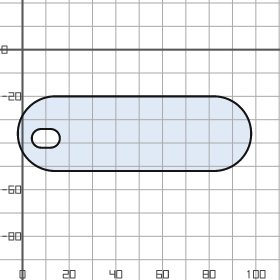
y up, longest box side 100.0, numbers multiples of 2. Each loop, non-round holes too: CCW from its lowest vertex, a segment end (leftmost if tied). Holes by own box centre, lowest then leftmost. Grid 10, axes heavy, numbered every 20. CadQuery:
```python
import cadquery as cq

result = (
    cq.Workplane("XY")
    .moveTo(14.0, -52.0)
    .lineTo(82.0, -52.0)
    .threePointArc((98.0, -36.0), (82.0, -20.0))
    .lineTo(14.0, -20.0)
    .threePointArc((-2.0, -36.0), (14.0, -52.0))
    .close()
    .moveTo(8.0, -42.0)
    .lineTo(12.0, -42.0)
    .threePointArc((16.0, -38.0), (12.0, -34.0))
    .lineTo(8.0, -34.0)
    .threePointArc((4.0, -38.0), (8.0, -42.0))
    .close()
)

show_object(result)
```